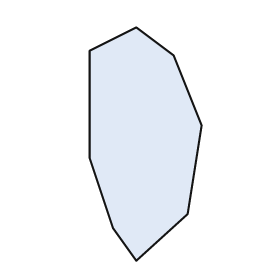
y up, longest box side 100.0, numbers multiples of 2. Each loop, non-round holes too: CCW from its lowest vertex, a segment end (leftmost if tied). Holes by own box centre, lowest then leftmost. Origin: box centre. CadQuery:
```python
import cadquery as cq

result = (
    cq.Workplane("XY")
    .moveTo(-4.0, -50.0)
    .lineTo(18.0, -30.0)
    .lineTo(24.0, 8.0)
    .lineTo(12.0, 38.0)
    .lineTo(-4.0, 50.0)
    .lineTo(-24.0, 40.0)
    .lineTo(-24.0, -6.0)
    .lineTo(-14.0, -36.0)
    .close()
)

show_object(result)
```